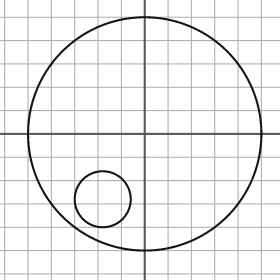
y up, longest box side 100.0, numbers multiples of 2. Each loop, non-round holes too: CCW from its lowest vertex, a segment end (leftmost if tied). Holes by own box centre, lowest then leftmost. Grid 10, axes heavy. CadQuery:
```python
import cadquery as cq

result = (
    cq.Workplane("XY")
    .moveTo(0.0, 0.0)
    .circle(50.0)
    .moveTo(-18.0, -28.0)
    .circle(12.0)
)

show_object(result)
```